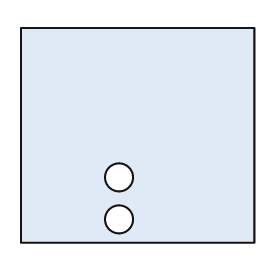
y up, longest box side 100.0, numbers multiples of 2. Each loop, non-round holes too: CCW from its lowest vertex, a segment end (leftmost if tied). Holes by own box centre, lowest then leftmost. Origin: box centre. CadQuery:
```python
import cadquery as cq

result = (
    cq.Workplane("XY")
    .moveTo(-50.0, -46.0)
    .lineTo(50.0, -46.0)
    .lineTo(50.0, 46.0)
    .lineTo(-50.0, 46.0)
    .close()
    .moveTo(-8.0, -36.0)
    .circle(6.0)
    .moveTo(-8.0, -18.0)
    .circle(6.0)
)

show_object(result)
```